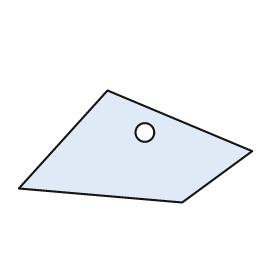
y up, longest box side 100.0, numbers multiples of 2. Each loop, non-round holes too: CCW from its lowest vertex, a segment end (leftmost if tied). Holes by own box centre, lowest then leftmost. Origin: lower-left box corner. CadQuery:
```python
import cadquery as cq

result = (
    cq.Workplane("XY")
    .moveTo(70.0, 0.0)
    .lineTo(100.0, 22.0)
    .lineTo(38.0, 48.0)
    .lineTo(0.0, 6.0)
    .close()
    .moveTo(54.0, 30.0)
    .circle(4.0)
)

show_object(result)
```